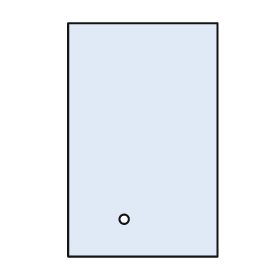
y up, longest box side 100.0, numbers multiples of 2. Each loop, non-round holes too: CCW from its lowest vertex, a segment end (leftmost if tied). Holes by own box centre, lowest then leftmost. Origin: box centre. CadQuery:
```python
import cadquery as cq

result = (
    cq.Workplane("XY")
    .moveTo(-32.0, -50.0)
    .lineTo(32.0, -50.0)
    .lineTo(32.0, 50.0)
    .lineTo(-32.0, 50.0)
    .close()
    .moveTo(-8.0, -34.0)
    .circle(2.0)
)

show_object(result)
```